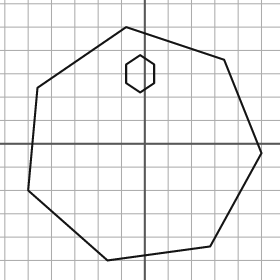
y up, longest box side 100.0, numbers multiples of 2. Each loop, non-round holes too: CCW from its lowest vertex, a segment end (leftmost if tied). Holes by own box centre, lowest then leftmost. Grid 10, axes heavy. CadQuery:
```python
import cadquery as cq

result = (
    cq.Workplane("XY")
    .moveTo(-16.0, -50.0)
    .lineTo(28.0, -44.0)
    .lineTo(50.0, -4.0)
    .lineTo(34.0, 36.0)
    .lineTo(-8.0, 50.0)
    .lineTo(-46.0, 24.0)
    .lineTo(-50.0, -20.0)
    .close()
    .moveTo(-2.0, 22.0)
    .lineTo(4.0, 26.0)
    .lineTo(4.0, 34.0)
    .lineTo(-2.0, 38.0)
    .lineTo(-8.0, 34.0)
    .lineTo(-8.0, 26.0)
    .close()
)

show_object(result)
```